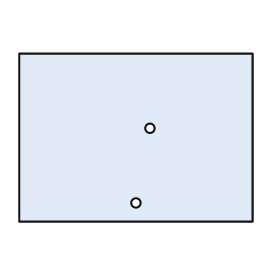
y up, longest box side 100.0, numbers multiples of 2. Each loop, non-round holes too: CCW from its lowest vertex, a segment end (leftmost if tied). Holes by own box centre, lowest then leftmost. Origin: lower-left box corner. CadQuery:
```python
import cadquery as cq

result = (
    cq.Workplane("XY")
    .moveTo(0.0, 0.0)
    .lineTo(100.0, 0.0)
    .lineTo(100.0, 72.0)
    .lineTo(0.0, 72.0)
    .close()
    .moveTo(50.0, 8.0)
    .circle(2.0)
    .moveTo(56.0, 40.0)
    .circle(2.0)
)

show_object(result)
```